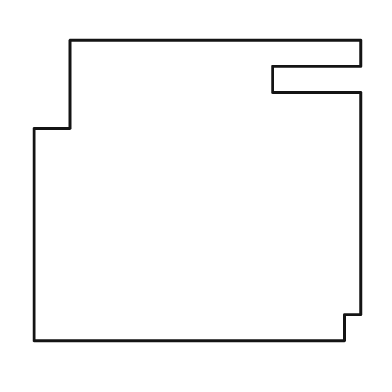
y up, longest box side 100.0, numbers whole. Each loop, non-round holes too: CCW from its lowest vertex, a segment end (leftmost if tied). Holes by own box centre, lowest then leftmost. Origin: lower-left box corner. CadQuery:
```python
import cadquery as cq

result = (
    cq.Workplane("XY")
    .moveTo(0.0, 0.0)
    .lineTo(95.0, 0.0)
    .lineTo(95.0, 8.0)
    .lineTo(100.0, 8.0)
    .lineTo(100.0, 76.0)
    .lineTo(73.0, 76.0)
    .lineTo(73.0, 84.0)
    .lineTo(100.0, 84.0)
    .lineTo(100.0, 92.0)
    .lineTo(11.0, 92.0)
    .lineTo(11.0, 65.0)
    .lineTo(0.0, 65.0)
    .close()
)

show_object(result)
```